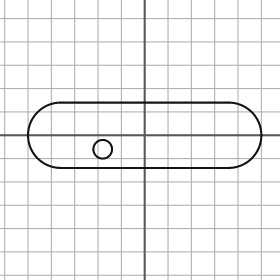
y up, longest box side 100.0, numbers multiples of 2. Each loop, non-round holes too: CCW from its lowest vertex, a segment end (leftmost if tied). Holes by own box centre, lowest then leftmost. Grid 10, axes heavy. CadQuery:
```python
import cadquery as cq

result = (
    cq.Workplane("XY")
    .moveTo(-36.0, -14.0)
    .lineTo(36.0, -14.0)
    .threePointArc((50.0, 0.0), (36.0, 14.0))
    .lineTo(-36.0, 14.0)
    .threePointArc((-50.0, 0.0), (-36.0, -14.0))
    .close()
    .moveTo(-18.0, -6.0)
    .circle(4.0)
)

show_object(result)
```